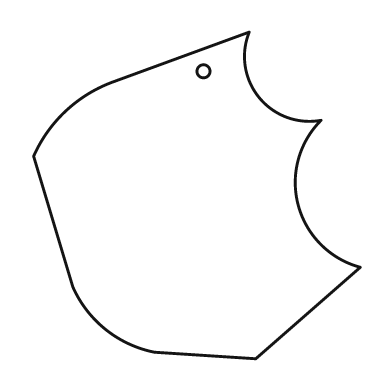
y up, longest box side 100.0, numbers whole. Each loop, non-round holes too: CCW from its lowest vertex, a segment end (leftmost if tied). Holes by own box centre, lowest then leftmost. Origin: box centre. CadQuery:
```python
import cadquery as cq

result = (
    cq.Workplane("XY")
    .moveTo(18.0, -50.0)
    .lineTo(50.0, -22.0)
    .threePointArc((31.0, -3.0), (38.0, 23.0))
    .threePointArc((19.0, 30.0), (16.0, 50.0))
    .lineTo(-25.0, 35.0)
    .threePointArc((-40.0, 26.0), (-50.0, 12.0))
    .lineTo(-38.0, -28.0)
    .threePointArc((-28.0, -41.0), (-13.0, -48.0))
    .close()
    .moveTo(2.0, 38.0)
    .circle(2.0)
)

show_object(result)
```